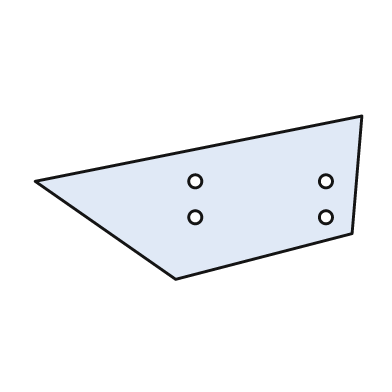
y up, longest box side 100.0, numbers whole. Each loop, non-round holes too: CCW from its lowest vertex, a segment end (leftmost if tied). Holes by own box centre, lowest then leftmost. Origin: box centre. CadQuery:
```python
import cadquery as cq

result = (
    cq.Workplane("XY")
    .moveTo(-7.0, -25.0)
    .lineTo(47.0, -11.0)
    .lineTo(50.0, 25.0)
    .lineTo(-50.0, 5.0)
    .close()
    .moveTo(-1.0, -6.0)
    .circle(2.0)
    .moveTo(39.0, -6.0)
    .circle(2.0)
    .moveTo(-1.0, 5.0)
    .circle(2.0)
    .moveTo(39.0, 5.0)
    .circle(2.0)
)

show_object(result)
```